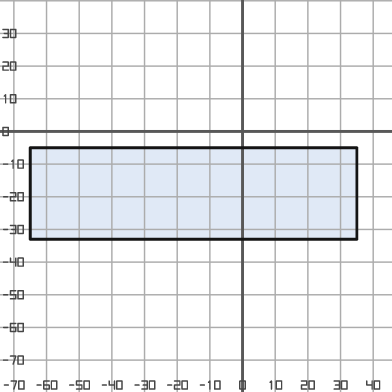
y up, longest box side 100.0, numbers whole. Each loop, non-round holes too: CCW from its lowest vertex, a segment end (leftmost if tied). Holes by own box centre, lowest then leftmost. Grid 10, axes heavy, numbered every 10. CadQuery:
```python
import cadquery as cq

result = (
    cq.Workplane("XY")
    .moveTo(-65.0, -33.0)
    .lineTo(35.0, -33.0)
    .lineTo(35.0, -5.0)
    .lineTo(-65.0, -5.0)
    .close()
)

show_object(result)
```